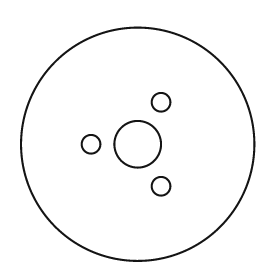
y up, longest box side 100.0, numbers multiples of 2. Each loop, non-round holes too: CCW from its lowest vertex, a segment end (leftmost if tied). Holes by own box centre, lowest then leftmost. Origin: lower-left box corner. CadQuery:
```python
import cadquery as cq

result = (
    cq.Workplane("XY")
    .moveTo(50.0, 50.0)
    .circle(50.0)
    .moveTo(60.0, 32.0)
    .circle(4.0)
    .moveTo(30.0, 50.0)
    .circle(4.0)
    .moveTo(50.0, 50.0)
    .circle(10.0)
    .moveTo(60.0, 68.0)
    .circle(4.0)
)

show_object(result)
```